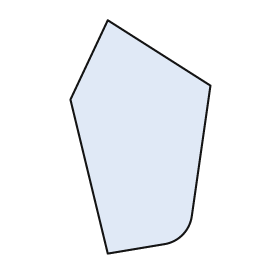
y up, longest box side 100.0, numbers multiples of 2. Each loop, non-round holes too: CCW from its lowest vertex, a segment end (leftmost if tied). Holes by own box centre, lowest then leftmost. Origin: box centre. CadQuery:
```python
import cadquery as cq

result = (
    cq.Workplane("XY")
    .moveTo(-14.0, -50.0)
    .lineTo(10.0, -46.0)
    .threePointArc((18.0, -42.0), (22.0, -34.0))
    .lineTo(30.0, 22.0)
    .lineTo(-14.0, 50.0)
    .lineTo(-30.0, 16.0)
    .close()
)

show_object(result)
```